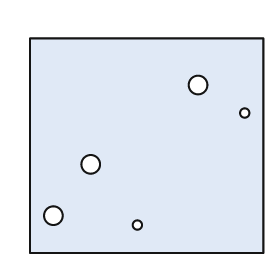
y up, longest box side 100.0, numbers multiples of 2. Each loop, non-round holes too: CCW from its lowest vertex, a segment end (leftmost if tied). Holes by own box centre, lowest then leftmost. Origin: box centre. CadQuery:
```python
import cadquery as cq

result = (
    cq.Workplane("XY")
    .moveTo(-50.0, -46.0)
    .lineTo(50.0, -46.0)
    .lineTo(50.0, 46.0)
    .lineTo(-50.0, 46.0)
    .close()
    .moveTo(-4.0, -34.0)
    .circle(2.0)
    .moveTo(-40.0, -30.0)
    .circle(4.0)
    .moveTo(-24.0, -8.0)
    .circle(4.0)
    .moveTo(42.0, 14.0)
    .circle(2.0)
    .moveTo(22.0, 26.0)
    .circle(4.0)
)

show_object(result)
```